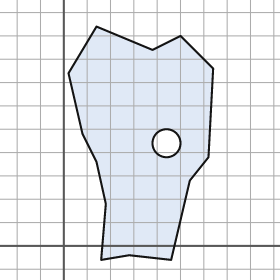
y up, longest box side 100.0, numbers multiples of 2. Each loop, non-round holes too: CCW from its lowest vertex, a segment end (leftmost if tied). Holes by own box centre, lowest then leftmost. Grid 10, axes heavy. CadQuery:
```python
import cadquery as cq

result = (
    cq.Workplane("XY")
    .moveTo(16.0, -6.0)
    .lineTo(28.0, -4.0)
    .lineTo(46.0, -6.0)
    .lineTo(54.0, 28.0)
    .lineTo(62.0, 38.0)
    .lineTo(64.0, 76.0)
    .lineTo(50.0, 90.0)
    .lineTo(38.0, 84.0)
    .lineTo(14.0, 94.0)
    .lineTo(2.0, 74.0)
    .lineTo(8.0, 48.0)
    .lineTo(14.0, 36.0)
    .lineTo(18.0, 18.0)
    .close()
    .moveTo(44.0, 44.0)
    .circle(6.0)
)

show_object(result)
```